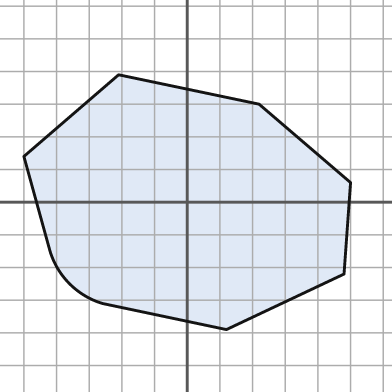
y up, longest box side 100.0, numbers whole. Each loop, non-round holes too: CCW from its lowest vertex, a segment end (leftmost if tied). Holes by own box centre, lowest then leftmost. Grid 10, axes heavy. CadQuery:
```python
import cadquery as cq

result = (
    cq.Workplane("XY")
    .moveTo(12.0, -39.0)
    .lineTo(48.0, -22.0)
    .lineTo(50.0, 6.0)
    .lineTo(22.0, 30.0)
    .lineTo(-21.0, 39.0)
    .lineTo(-50.0, 14.0)
    .lineTo(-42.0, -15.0)
    .threePointArc((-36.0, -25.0), (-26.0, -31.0))
    .close()
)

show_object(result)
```